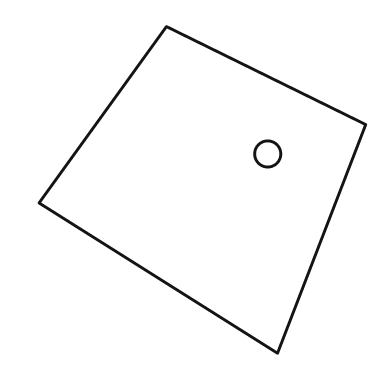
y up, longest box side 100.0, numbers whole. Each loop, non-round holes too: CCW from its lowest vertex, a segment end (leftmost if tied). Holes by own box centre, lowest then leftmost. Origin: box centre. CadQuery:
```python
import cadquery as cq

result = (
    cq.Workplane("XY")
    .moveTo(23.0, -50.0)
    .lineTo(50.0, 20.0)
    .lineTo(-11.0, 50.0)
    .lineTo(-50.0, -4.0)
    .close()
    .moveTo(20.0, 11.0)
    .circle(4.0)
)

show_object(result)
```